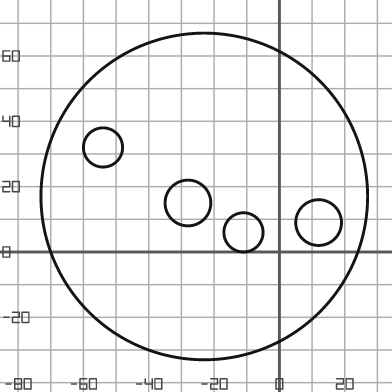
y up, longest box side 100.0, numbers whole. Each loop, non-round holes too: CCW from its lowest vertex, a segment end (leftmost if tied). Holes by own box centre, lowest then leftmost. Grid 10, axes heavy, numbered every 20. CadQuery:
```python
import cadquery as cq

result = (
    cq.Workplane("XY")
    .moveTo(-23.0, 17.0)
    .circle(50.0)
    .moveTo(-11.0, 6.0)
    .circle(6.0)
    .moveTo(12.0, 9.0)
    .circle(7.0)
    .moveTo(-28.0, 15.0)
    .circle(7.0)
    .moveTo(-54.0, 32.0)
    .circle(6.0)
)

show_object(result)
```